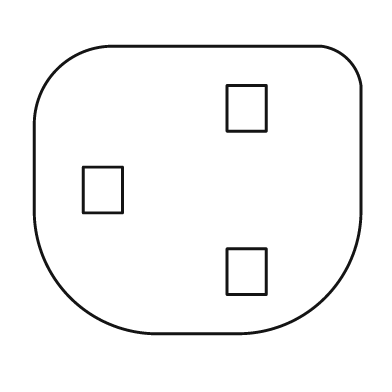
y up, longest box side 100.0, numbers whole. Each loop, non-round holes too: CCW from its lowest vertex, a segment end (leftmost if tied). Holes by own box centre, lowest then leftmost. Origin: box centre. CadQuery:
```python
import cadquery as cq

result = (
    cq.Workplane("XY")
    .moveTo(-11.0, -44.0)
    .lineTo(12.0, -44.0)
    .threePointArc((39.0, -33.0), (50.0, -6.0))
    .lineTo(50.0, 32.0)
    .threePointArc((46.0, 40.0), (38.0, 44.0))
    .lineTo(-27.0, 44.0)
    .threePointArc((-43.0, 37.0), (-50.0, 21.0))
    .lineTo(-50.0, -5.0)
    .threePointArc((-39.0, -33.0), (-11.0, -44.0))
    .close()
    .moveTo(9.0, -32.0)
    .lineTo(21.0, -32.0)
    .lineTo(21.0, -18.0)
    .lineTo(9.0, -18.0)
    .close()
    .moveTo(-35.0, -7.0)
    .lineTo(-23.0, -7.0)
    .lineTo(-23.0, 7.0)
    .lineTo(-35.0, 7.0)
    .close()
    .moveTo(9.0, 18.0)
    .lineTo(21.0, 18.0)
    .lineTo(21.0, 32.0)
    .lineTo(9.0, 32.0)
    .close()
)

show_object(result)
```